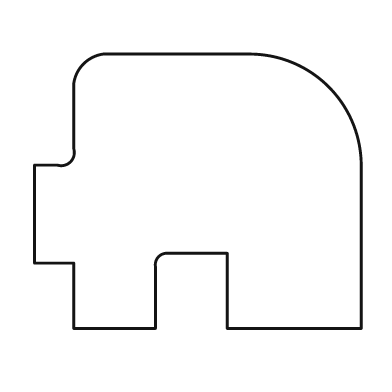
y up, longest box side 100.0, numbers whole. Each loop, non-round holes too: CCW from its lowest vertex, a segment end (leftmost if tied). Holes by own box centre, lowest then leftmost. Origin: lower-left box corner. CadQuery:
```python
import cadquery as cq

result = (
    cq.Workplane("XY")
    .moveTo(12.0, 0.0)
    .lineTo(37.0, 0.0)
    .lineTo(37.0, 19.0)
    .threePointArc((38.0, 22.0), (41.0, 23.0))
    .lineTo(59.0, 23.0)
    .lineTo(59.0, 0.0)
    .lineTo(100.0, 0.0)
    .lineTo(100.0, 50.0)
    .threePointArc((90.0, 74.0), (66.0, 84.0))
    .lineTo(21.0, 84.0)
    .threePointArc((15.0, 81.0), (12.0, 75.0))
    .lineTo(12.0, 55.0)
    .threePointArc((11.0, 51.0), (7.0, 50.0))
    .lineTo(0.0, 50.0)
    .lineTo(0.0, 20.0)
    .lineTo(12.0, 20.0)
    .close()
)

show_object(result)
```